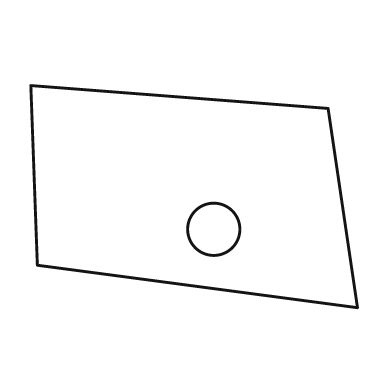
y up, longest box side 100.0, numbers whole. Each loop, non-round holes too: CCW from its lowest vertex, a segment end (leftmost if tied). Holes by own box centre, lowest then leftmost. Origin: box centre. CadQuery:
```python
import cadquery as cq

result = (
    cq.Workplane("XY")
    .moveTo(50.0, -34.0)
    .lineTo(41.0, 27.0)
    .lineTo(-50.0, 34.0)
    .lineTo(-48.0, -21.0)
    .close()
    .moveTo(6.0, -10.0)
    .circle(8.0)
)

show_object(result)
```